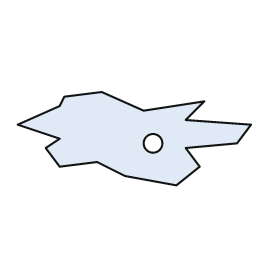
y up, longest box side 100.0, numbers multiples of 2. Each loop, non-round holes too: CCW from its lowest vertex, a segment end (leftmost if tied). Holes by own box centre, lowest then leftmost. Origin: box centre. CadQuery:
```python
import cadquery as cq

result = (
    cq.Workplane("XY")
    .moveTo(18.0, -20.0)
    .lineTo(28.0, -12.0)
    .lineTo(22.0, -4.0)
    .lineTo(44.0, -2.0)
    .lineTo(50.0, 6.0)
    .lineTo(22.0, 8.0)
    .lineTo(30.0, 16.0)
    .lineTo(4.0, 12.0)
    .lineTo(-14.0, 20.0)
    .lineTo(-30.0, 18.0)
    .lineTo(-32.0, 14.0)
    .lineTo(-50.0, 6.0)
    .lineTo(-32.0, 0.0)
    .lineTo(-38.0, -4.0)
    .lineTo(-32.0, -12.0)
    .lineTo(-16.0, -10.0)
    .lineTo(-4.0, -16.0)
    .close()
    .moveTo(8.0, -2.0)
    .circle(4.0)
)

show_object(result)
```